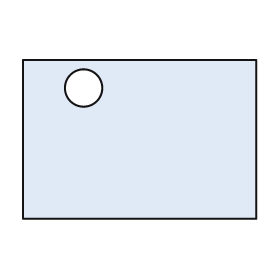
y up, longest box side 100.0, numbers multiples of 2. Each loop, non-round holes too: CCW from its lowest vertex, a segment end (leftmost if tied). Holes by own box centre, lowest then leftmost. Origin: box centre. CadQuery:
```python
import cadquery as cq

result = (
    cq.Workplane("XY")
    .moveTo(-50.0, -34.0)
    .lineTo(50.0, -34.0)
    .lineTo(50.0, 34.0)
    .lineTo(-50.0, 34.0)
    .close()
    .moveTo(-24.0, 22.0)
    .circle(8.0)
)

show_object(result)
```